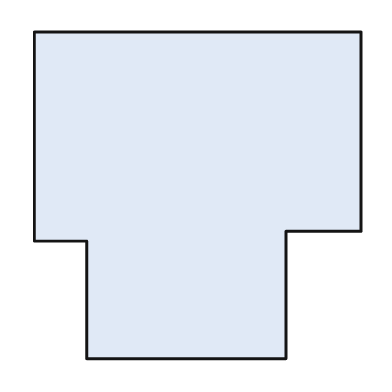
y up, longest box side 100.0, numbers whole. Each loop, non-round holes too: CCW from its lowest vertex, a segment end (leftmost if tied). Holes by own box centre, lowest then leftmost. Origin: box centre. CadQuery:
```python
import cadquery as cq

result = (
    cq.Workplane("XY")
    .moveTo(-34.0, -50.0)
    .lineTo(27.0, -50.0)
    .lineTo(27.0, -11.0)
    .lineTo(50.0, -11.0)
    .lineTo(50.0, 50.0)
    .lineTo(-50.0, 50.0)
    .lineTo(-50.0, -14.0)
    .lineTo(-34.0, -14.0)
    .close()
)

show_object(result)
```